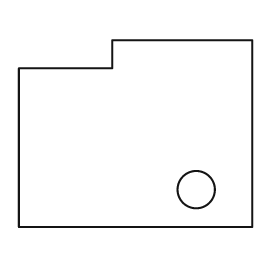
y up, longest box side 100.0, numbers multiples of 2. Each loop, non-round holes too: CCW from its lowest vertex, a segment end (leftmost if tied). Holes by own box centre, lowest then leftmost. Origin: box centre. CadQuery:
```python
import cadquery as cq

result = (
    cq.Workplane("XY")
    .moveTo(-50.0, -40.0)
    .lineTo(50.0, -40.0)
    .lineTo(50.0, 40.0)
    .lineTo(-10.0, 40.0)
    .lineTo(-10.0, 28.0)
    .lineTo(-50.0, 28.0)
    .close()
    .moveTo(26.0, -24.0)
    .circle(8.0)
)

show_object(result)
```